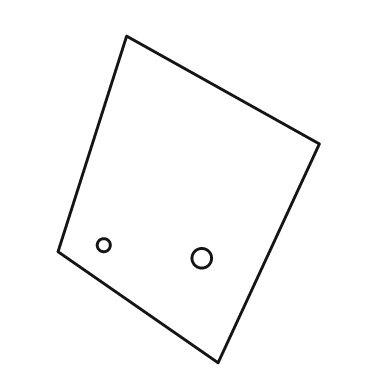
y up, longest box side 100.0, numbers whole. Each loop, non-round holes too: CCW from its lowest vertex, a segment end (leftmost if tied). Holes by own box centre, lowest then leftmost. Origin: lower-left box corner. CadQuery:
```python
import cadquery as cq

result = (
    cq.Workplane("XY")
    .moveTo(49.0, 0.0)
    .lineTo(80.0, 67.0)
    .lineTo(21.0, 100.0)
    .lineTo(0.0, 34.0)
    .close()
    .moveTo(44.0, 32.0)
    .circle(3.0)
    .moveTo(14.0, 36.0)
    .circle(2.0)
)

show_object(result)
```